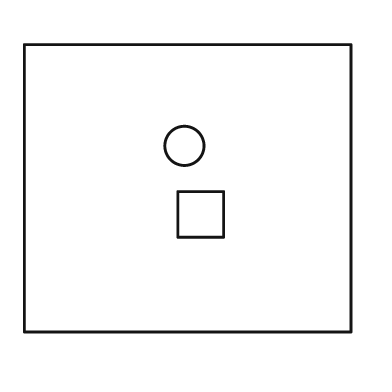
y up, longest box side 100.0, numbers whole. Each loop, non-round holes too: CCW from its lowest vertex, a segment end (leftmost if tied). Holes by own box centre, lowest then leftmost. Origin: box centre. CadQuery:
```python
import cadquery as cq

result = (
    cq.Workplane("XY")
    .moveTo(-50.0, -44.0)
    .lineTo(50.0, -44.0)
    .lineTo(50.0, 44.0)
    .lineTo(-50.0, 44.0)
    .close()
    .moveTo(-3.0, -15.0)
    .lineTo(11.0, -15.0)
    .lineTo(11.0, -1.0)
    .lineTo(-3.0, -1.0)
    .close()
    .moveTo(-1.0, 13.0)
    .circle(6.0)
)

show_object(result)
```